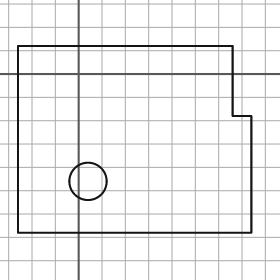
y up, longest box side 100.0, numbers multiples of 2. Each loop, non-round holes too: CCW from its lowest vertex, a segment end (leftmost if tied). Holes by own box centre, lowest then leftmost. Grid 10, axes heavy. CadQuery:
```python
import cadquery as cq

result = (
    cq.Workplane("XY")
    .moveTo(-26.0, -68.0)
    .lineTo(74.0, -68.0)
    .lineTo(74.0, -18.0)
    .lineTo(66.0, -18.0)
    .lineTo(66.0, 12.0)
    .lineTo(-26.0, 12.0)
    .close()
    .moveTo(4.0, -46.0)
    .circle(8.0)
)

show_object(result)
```